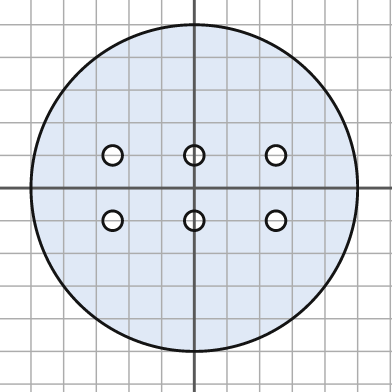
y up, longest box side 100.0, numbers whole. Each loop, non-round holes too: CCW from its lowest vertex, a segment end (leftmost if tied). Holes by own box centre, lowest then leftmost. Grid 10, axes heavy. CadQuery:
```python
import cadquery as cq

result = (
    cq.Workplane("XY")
    .moveTo(0.0, 0.0)
    .circle(50.0)
    .moveTo(-25.0, -10.0)
    .circle(3.0)
    .moveTo(0.0, -10.0)
    .circle(3.0)
    .moveTo(25.0, -10.0)
    .circle(3.0)
    .moveTo(-25.0, 10.0)
    .circle(3.0)
    .moveTo(0.0, 10.0)
    .circle(3.0)
    .moveTo(25.0, 10.0)
    .circle(3.0)
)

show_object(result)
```